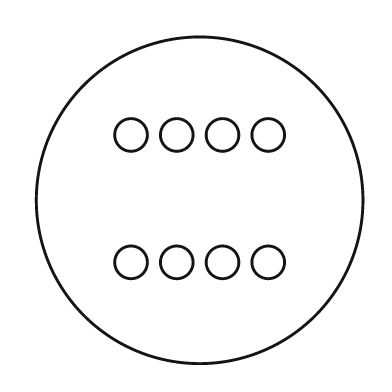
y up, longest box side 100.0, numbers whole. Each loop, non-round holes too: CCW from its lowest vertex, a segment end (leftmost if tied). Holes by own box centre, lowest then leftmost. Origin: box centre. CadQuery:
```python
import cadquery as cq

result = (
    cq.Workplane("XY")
    .moveTo(0.0, 0.0)
    .circle(50.0)
    .moveTo(-21.0, -19.0)
    .circle(5.0)
    .moveTo(-7.0, -19.0)
    .circle(5.0)
    .moveTo(7.0, -19.0)
    .circle(5.0)
    .moveTo(21.0, -19.0)
    .circle(5.0)
    .moveTo(-21.0, 20.0)
    .circle(5.0)
    .moveTo(-7.0, 20.0)
    .circle(5.0)
    .moveTo(7.0, 20.0)
    .circle(5.0)
    .moveTo(21.0, 20.0)
    .circle(5.0)
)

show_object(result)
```